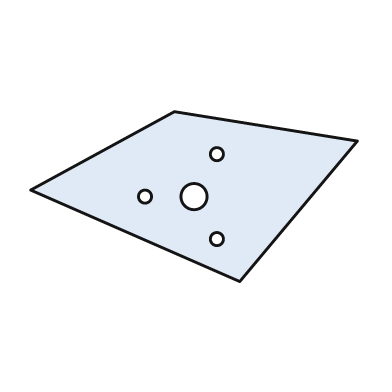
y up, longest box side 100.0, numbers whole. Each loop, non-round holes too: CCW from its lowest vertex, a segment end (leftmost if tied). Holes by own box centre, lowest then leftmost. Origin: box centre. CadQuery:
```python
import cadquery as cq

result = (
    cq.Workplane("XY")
    .moveTo(14.0, -26.0)
    .lineTo(50.0, 17.0)
    .lineTo(-6.0, 26.0)
    .lineTo(-50.0, 2.0)
    .close()
    .moveTo(7.0, -13.0)
    .circle(2.0)
    .moveTo(-15.0, 0.0)
    .circle(2.0)
    .moveTo(0.0, 0.0)
    .circle(4.0)
    .moveTo(7.0, 13.0)
    .circle(2.0)
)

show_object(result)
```